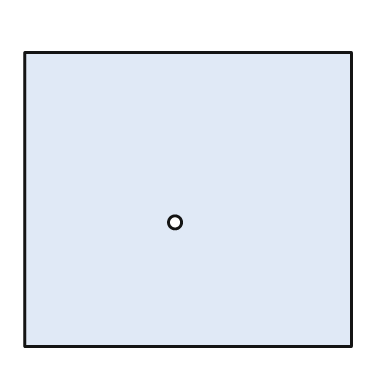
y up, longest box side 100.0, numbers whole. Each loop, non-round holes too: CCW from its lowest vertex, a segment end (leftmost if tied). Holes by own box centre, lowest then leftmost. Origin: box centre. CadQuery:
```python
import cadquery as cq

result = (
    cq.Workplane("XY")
    .moveTo(-50.0, -45.0)
    .lineTo(50.0, -45.0)
    .lineTo(50.0, 45.0)
    .lineTo(-50.0, 45.0)
    .close()
    .moveTo(-4.0, -7.0)
    .circle(2.0)
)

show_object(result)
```